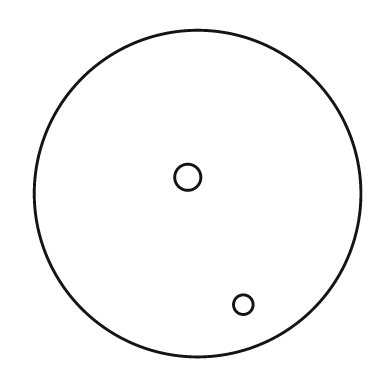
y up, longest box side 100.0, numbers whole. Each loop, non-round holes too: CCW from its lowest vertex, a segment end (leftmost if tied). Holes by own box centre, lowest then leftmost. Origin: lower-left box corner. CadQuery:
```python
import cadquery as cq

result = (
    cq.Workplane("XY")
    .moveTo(50.0, 50.0)
    .circle(50.0)
    .moveTo(64.0, 16.0)
    .circle(3.0)
    .moveTo(47.0, 55.0)
    .circle(4.0)
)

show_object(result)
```